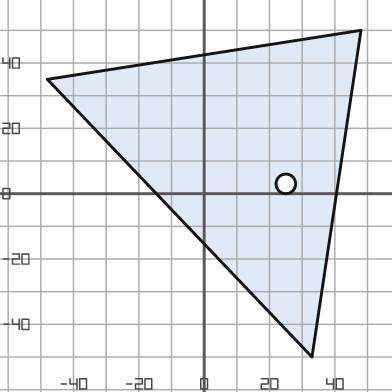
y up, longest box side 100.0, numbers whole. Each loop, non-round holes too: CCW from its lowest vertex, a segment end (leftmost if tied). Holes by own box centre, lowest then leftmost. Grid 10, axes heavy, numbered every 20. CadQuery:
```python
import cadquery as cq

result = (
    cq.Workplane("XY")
    .moveTo(33.0, -50.0)
    .lineTo(48.0, 50.0)
    .lineTo(-48.0, 35.0)
    .close()
    .moveTo(25.0, 3.0)
    .circle(3.0)
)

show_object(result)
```